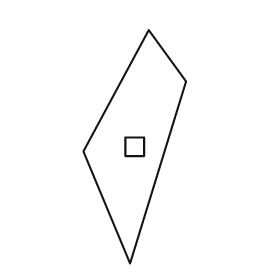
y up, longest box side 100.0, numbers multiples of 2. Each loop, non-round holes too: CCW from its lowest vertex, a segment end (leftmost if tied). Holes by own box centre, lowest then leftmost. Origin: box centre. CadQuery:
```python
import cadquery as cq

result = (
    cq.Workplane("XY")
    .moveTo(-2.0, -50.0)
    .lineTo(22.0, 28.0)
    .lineTo(6.0, 50.0)
    .lineTo(-22.0, -2.0)
    .close()
    .moveTo(-4.0, -4.0)
    .lineTo(4.0, -4.0)
    .lineTo(4.0, 4.0)
    .lineTo(-4.0, 4.0)
    .close()
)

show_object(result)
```